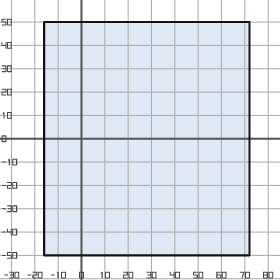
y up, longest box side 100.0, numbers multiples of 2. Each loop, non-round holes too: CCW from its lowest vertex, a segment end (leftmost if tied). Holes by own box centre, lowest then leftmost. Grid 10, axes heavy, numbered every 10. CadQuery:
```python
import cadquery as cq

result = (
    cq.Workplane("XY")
    .moveTo(-16.0, -50.0)
    .lineTo(72.0, -50.0)
    .lineTo(72.0, 50.0)
    .lineTo(-16.0, 50.0)
    .close()
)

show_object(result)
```